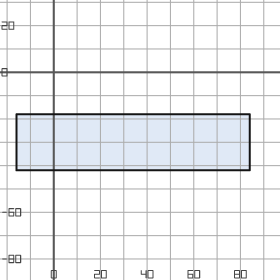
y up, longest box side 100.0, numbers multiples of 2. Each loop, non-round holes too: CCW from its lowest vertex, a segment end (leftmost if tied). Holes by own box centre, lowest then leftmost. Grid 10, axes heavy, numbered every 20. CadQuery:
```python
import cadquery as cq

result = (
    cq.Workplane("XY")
    .moveTo(-16.0, -42.0)
    .lineTo(84.0, -42.0)
    .lineTo(84.0, -18.0)
    .lineTo(-16.0, -18.0)
    .close()
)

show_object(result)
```